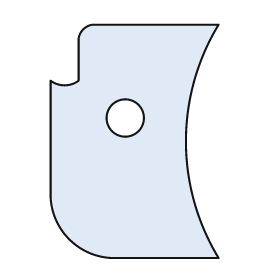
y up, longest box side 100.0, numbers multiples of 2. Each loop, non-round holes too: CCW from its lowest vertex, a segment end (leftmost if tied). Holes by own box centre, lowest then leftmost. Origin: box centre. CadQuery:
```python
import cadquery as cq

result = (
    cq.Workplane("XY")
    .moveTo(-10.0, -50.0)
    .lineTo(36.0, -50.0)
    .threePointArc((22.0, 0.0), (36.0, 50.0))
    .lineTo(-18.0, 50.0)
    .threePointArc((-22.0, 48.0), (-24.0, 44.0))
    .lineTo(-24.0, 26.0)
    .threePointArc((-30.0, 24.0), (-36.0, 26.0))
    .lineTo(-36.0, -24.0)
    .threePointArc((-28.0, -42.0), (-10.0, -50.0))
    .close()
    .moveTo(-4.0, 10.0)
    .circle(8.0)
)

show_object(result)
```